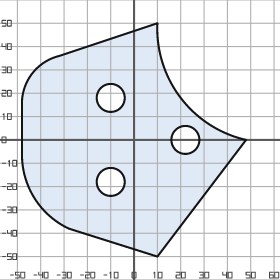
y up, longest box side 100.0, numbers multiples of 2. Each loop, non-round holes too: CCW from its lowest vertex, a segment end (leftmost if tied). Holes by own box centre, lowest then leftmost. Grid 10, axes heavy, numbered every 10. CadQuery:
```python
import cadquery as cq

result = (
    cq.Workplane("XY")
    .moveTo(10.0, -50.0)
    .lineTo(48.0, 0.0)
    .threePointArc((20.0, 18.0), (10.0, 50.0))
    .lineTo(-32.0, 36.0)
    .threePointArc((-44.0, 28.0), (-48.0, 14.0))
    .lineTo(-48.0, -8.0)
    .threePointArc((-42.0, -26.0), (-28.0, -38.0))
    .close()
    .moveTo(-10.0, -18.0)
    .circle(6.0)
    .moveTo(22.0, 0.0)
    .circle(6.0)
    .moveTo(-10.0, 18.0)
    .circle(6.0)
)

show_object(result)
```